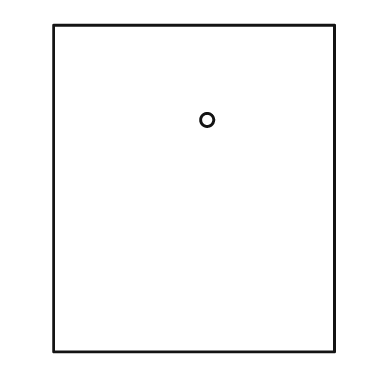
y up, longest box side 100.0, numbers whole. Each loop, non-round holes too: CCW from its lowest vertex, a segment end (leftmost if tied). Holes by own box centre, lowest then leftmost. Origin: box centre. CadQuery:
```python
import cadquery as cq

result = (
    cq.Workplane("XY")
    .moveTo(-43.0, -50.0)
    .lineTo(43.0, -50.0)
    .lineTo(43.0, 50.0)
    .lineTo(-43.0, 50.0)
    .close()
    .moveTo(4.0, 21.0)
    .circle(2.0)
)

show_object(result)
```